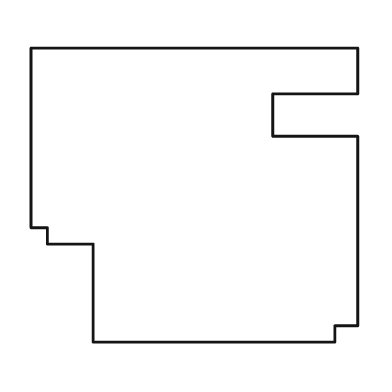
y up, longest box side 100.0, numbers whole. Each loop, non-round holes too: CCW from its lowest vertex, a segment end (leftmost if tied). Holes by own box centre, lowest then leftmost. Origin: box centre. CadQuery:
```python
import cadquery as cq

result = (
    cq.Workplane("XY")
    .moveTo(-31.0, -45.0)
    .lineTo(43.0, -45.0)
    .lineTo(43.0, -40.0)
    .lineTo(50.0, -40.0)
    .lineTo(50.0, 18.0)
    .lineTo(24.0, 18.0)
    .lineTo(24.0, 31.0)
    .lineTo(50.0, 31.0)
    .lineTo(50.0, 45.0)
    .lineTo(-50.0, 45.0)
    .lineTo(-50.0, -10.0)
    .lineTo(-45.0, -10.0)
    .lineTo(-45.0, -15.0)
    .lineTo(-31.0, -15.0)
    .close()
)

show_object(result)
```